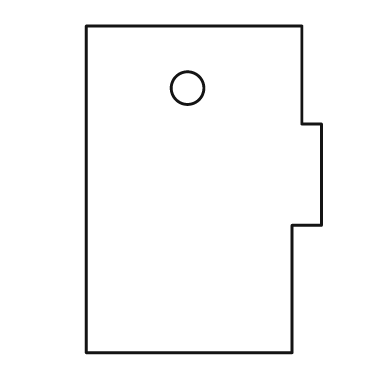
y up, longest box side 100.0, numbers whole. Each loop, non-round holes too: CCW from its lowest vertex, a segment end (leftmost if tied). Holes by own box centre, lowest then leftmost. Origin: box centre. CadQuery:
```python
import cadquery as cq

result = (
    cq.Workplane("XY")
    .moveTo(-36.0, -50.0)
    .lineTo(27.0, -50.0)
    .lineTo(27.0, -11.0)
    .lineTo(36.0, -11.0)
    .lineTo(36.0, 20.0)
    .lineTo(30.0, 20.0)
    .lineTo(30.0, 50.0)
    .lineTo(-36.0, 50.0)
    .close()
    .moveTo(-5.0, 31.0)
    .circle(5.0)
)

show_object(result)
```